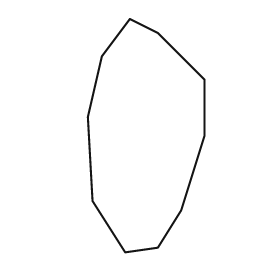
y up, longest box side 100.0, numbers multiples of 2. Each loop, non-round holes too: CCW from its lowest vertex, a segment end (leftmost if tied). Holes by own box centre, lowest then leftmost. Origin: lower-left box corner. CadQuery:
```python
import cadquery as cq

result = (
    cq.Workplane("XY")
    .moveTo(16.0, 0.0)
    .lineTo(30.0, 2.0)
    .lineTo(40.0, 18.0)
    .lineTo(50.0, 50.0)
    .lineTo(50.0, 74.0)
    .lineTo(30.0, 94.0)
    .lineTo(18.0, 100.0)
    .lineTo(6.0, 84.0)
    .lineTo(0.0, 58.0)
    .lineTo(2.0, 22.0)
    .close()
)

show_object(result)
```